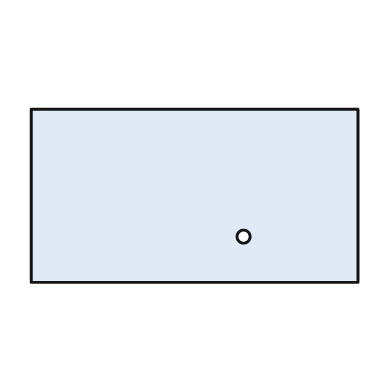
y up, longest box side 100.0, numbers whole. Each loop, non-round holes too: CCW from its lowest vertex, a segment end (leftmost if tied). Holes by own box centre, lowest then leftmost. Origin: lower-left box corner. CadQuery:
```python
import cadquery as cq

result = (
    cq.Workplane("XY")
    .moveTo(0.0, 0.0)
    .lineTo(100.0, 0.0)
    .lineTo(100.0, 53.0)
    .lineTo(0.0, 53.0)
    .close()
    .moveTo(65.0, 14.0)
    .circle(2.0)
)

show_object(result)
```